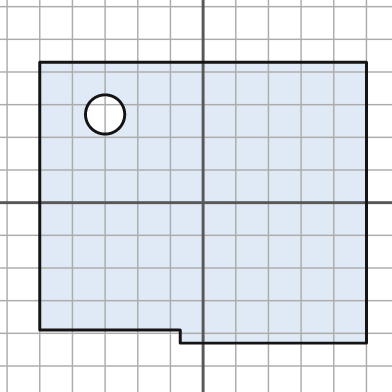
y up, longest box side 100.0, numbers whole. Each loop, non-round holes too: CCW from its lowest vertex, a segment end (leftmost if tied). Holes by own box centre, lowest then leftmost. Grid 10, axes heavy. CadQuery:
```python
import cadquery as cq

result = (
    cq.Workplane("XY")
    .moveTo(-7.0, -43.0)
    .lineTo(50.0, -43.0)
    .lineTo(50.0, 43.0)
    .lineTo(-50.0, 43.0)
    .lineTo(-50.0, -39.0)
    .lineTo(-7.0, -39.0)
    .close()
    .moveTo(-30.0, 27.0)
    .circle(6.0)
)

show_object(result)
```